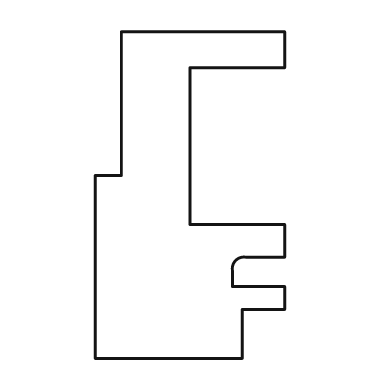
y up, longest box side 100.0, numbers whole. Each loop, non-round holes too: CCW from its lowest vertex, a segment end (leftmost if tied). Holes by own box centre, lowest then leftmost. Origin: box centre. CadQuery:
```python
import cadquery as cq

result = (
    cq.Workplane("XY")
    .moveTo(-29.0, -50.0)
    .lineTo(16.0, -50.0)
    .lineTo(16.0, -35.0)
    .lineTo(29.0, -35.0)
    .lineTo(29.0, -28.0)
    .lineTo(13.0, -28.0)
    .lineTo(13.0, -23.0)
    .threePointArc((14.0, -20.0), (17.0, -19.0))
    .lineTo(29.0, -19.0)
    .lineTo(29.0, -9.0)
    .lineTo(0.0, -9.0)
    .lineTo(0.0, 39.0)
    .lineTo(29.0, 39.0)
    .lineTo(29.0, 50.0)
    .lineTo(-21.0, 50.0)
    .lineTo(-21.0, 6.0)
    .lineTo(-29.0, 6.0)
    .close()
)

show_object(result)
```